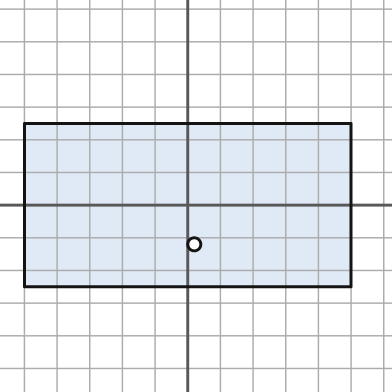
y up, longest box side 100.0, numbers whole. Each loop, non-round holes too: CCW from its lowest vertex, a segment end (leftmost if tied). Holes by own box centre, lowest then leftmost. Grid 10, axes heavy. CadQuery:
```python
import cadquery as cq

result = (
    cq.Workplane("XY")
    .moveTo(-50.0, -25.0)
    .lineTo(50.0, -25.0)
    .lineTo(50.0, 25.0)
    .lineTo(-50.0, 25.0)
    .close()
    .moveTo(2.0, -12.0)
    .circle(2.0)
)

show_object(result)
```